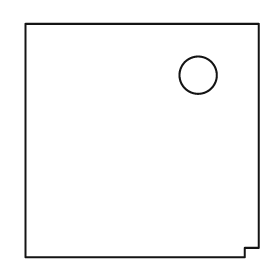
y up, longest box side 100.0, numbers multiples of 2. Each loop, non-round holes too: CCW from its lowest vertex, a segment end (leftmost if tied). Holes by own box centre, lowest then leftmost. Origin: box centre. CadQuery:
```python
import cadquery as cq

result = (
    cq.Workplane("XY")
    .moveTo(-50.0, -50.0)
    .lineTo(44.0, -50.0)
    .lineTo(44.0, -46.0)
    .lineTo(50.0, -46.0)
    .lineTo(50.0, 50.0)
    .lineTo(-50.0, 50.0)
    .close()
    .moveTo(24.0, 28.0)
    .circle(8.0)
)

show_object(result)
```